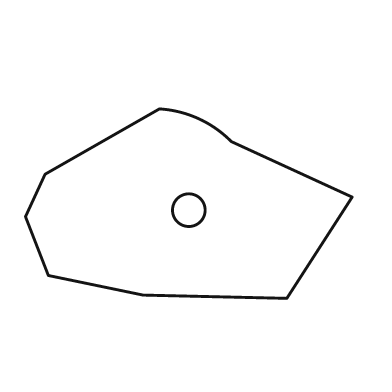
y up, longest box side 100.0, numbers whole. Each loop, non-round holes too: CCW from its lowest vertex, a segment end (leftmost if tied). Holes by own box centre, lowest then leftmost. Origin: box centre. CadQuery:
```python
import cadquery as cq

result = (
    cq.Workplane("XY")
    .moveTo(30.0, -29.0)
    .lineTo(50.0, 2.0)
    .lineTo(13.0, 19.0)
    .threePointArc((3.0, 26.0), (-9.0, 29.0))
    .lineTo(-44.0, 9.0)
    .lineTo(-50.0, -4.0)
    .lineTo(-43.0, -22.0)
    .lineTo(-14.0, -28.0)
    .close()
    .moveTo(0.0, -2.0)
    .circle(5.0)
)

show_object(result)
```